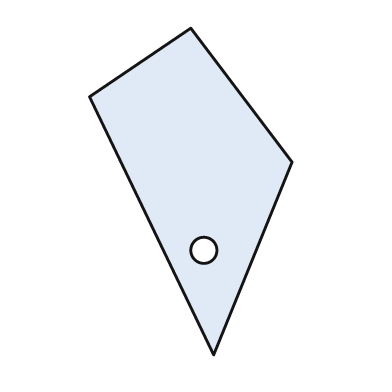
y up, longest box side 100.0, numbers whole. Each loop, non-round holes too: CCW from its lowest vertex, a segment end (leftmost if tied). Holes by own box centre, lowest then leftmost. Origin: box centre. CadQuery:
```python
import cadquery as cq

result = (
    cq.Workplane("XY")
    .moveTo(7.0, -50.0)
    .lineTo(31.0, 9.0)
    .lineTo(0.0, 50.0)
    .lineTo(-31.0, 29.0)
    .close()
    .moveTo(4.0, -18.0)
    .circle(4.0)
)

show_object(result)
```